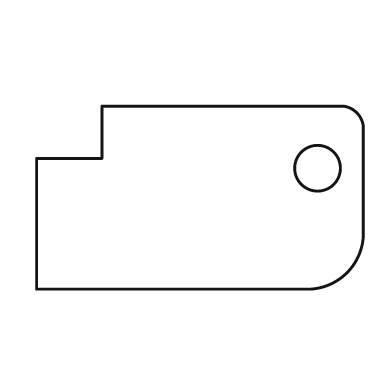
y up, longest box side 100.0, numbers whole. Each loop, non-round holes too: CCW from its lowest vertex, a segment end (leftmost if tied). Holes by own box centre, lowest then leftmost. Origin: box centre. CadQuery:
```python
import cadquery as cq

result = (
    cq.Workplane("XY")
    .moveTo(-50.0, -28.0)
    .lineTo(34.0, -28.0)
    .threePointArc((45.0, -23.0), (50.0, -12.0))
    .lineTo(50.0, 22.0)
    .threePointArc((48.0, 26.0), (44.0, 28.0))
    .lineTo(-30.0, 28.0)
    .lineTo(-30.0, 12.0)
    .lineTo(-50.0, 12.0)
    .close()
    .moveTo(36.0, 9.0)
    .circle(7.0)
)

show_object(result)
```